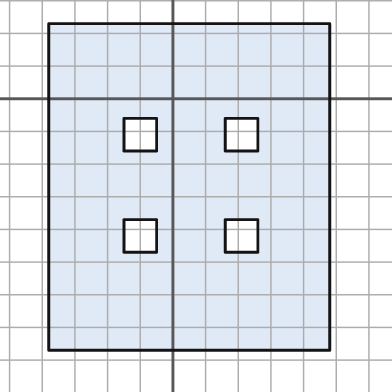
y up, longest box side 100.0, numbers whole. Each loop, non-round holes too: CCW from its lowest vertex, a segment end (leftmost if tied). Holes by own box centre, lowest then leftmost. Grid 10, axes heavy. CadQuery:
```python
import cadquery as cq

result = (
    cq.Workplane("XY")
    .moveTo(-38.0, -77.0)
    .lineTo(48.0, -77.0)
    .lineTo(48.0, 23.0)
    .lineTo(-38.0, 23.0)
    .close()
    .moveTo(-15.0, -47.0)
    .lineTo(-5.0, -47.0)
    .lineTo(-5.0, -37.0)
    .lineTo(-15.0, -37.0)
    .close()
    .moveTo(16.0, -47.0)
    .lineTo(26.0, -47.0)
    .lineTo(26.0, -37.0)
    .lineTo(16.0, -37.0)
    .close()
    .moveTo(-15.0, -16.0)
    .lineTo(-5.0, -16.0)
    .lineTo(-5.0, -6.0)
    .lineTo(-15.0, -6.0)
    .close()
    .moveTo(16.0, -16.0)
    .lineTo(26.0, -16.0)
    .lineTo(26.0, -6.0)
    .lineTo(16.0, -6.0)
    .close()
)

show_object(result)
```